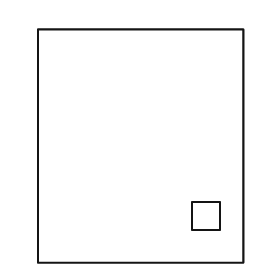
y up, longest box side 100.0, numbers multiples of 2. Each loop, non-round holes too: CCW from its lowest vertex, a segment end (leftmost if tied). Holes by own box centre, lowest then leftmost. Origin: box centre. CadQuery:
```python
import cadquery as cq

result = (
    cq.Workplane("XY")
    .moveTo(-44.0, -50.0)
    .lineTo(44.0, -50.0)
    .lineTo(44.0, 50.0)
    .lineTo(-44.0, 50.0)
    .close()
    .moveTo(22.0, -36.0)
    .lineTo(34.0, -36.0)
    .lineTo(34.0, -24.0)
    .lineTo(22.0, -24.0)
    .close()
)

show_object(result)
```